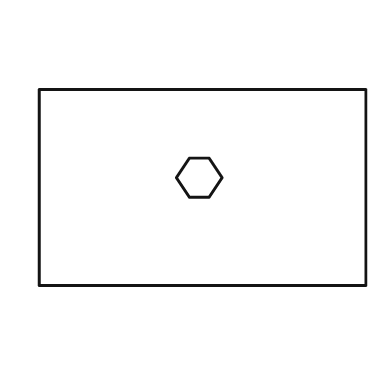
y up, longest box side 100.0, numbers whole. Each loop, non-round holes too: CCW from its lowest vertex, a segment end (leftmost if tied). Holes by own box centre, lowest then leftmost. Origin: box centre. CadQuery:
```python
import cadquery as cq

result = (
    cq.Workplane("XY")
    .moveTo(-50.0, -30.0)
    .lineTo(50.0, -30.0)
    .lineTo(50.0, 30.0)
    .lineTo(-50.0, 30.0)
    .close()
    .moveTo(-4.0, -3.0)
    .lineTo(2.0, -3.0)
    .lineTo(6.0, 3.0)
    .lineTo(2.0, 9.0)
    .lineTo(-4.0, 9.0)
    .lineTo(-8.0, 3.0)
    .close()
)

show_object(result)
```